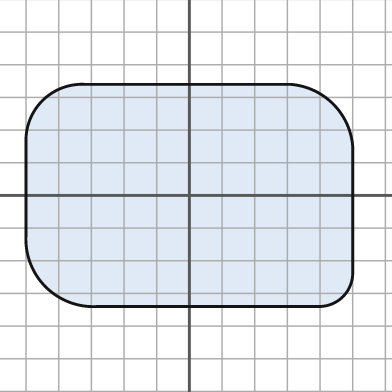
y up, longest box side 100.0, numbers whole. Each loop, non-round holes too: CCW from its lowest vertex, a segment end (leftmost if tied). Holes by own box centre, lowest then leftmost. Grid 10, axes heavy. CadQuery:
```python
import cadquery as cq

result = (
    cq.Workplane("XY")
    .moveTo(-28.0, -34.0)
    .lineTo(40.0, -34.0)
    .threePointArc((47.0, -31.0), (50.0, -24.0))
    .lineTo(50.0, 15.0)
    .threePointArc((44.0, 28.0), (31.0, 34.0))
    .lineTo(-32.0, 34.0)
    .threePointArc((-45.0, 29.0), (-50.0, 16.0))
    .lineTo(-50.0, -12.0)
    .threePointArc((-44.0, -28.0), (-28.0, -34.0))
    .close()
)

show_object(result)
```